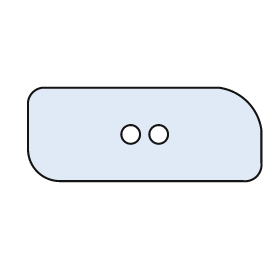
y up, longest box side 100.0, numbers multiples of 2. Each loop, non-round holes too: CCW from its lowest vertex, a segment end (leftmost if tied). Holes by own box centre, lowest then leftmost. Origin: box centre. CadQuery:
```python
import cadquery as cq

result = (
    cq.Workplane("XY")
    .moveTo(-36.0, -20.0)
    .lineTo(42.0, -20.0)
    .threePointArc((48.0, -18.0), (50.0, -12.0))
    .lineTo(50.0, 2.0)
    .threePointArc((44.0, 14.0), (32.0, 20.0))
    .lineTo(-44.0, 20.0)
    .threePointArc((-48.0, 18.0), (-50.0, 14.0))
    .lineTo(-50.0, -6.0)
    .threePointArc((-46.0, -16.0), (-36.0, -20.0))
    .close()
    .moveTo(-6.0, 0.0)
    .circle(4.0)
    .moveTo(6.0, 0.0)
    .circle(4.0)
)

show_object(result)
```